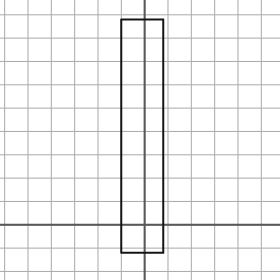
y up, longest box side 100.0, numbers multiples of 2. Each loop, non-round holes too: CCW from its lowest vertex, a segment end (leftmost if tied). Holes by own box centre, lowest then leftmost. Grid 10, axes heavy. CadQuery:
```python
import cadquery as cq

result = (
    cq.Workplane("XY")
    .moveTo(-10.0, -12.0)
    .lineTo(8.0, -12.0)
    .lineTo(8.0, 88.0)
    .lineTo(-10.0, 88.0)
    .close()
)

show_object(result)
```